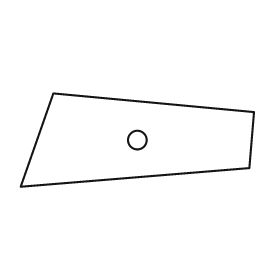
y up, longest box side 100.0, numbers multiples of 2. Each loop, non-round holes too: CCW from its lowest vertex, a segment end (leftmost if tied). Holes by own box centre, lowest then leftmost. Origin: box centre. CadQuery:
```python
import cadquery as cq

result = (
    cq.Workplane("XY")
    .moveTo(-50.0, -20.0)
    .lineTo(48.0, -12.0)
    .lineTo(50.0, 12.0)
    .lineTo(-36.0, 20.0)
    .close()
    .moveTo(0.0, 0.0)
    .circle(4.0)
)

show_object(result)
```